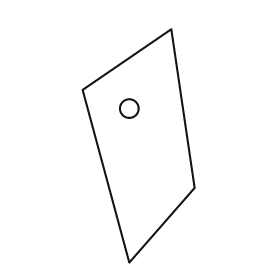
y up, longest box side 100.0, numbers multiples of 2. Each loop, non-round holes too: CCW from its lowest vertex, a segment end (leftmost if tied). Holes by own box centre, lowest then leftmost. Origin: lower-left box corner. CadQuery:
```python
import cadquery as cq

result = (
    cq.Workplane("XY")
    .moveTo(20.0, 0.0)
    .lineTo(48.0, 32.0)
    .lineTo(38.0, 100.0)
    .lineTo(0.0, 74.0)
    .close()
    .moveTo(20.0, 66.0)
    .circle(4.0)
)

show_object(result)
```